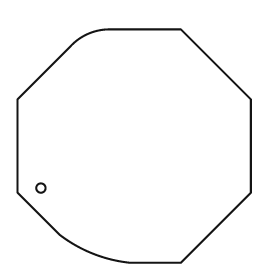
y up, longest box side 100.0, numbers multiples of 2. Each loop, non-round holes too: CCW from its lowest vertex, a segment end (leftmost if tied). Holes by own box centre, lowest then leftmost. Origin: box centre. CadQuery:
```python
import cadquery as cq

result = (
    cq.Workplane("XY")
    .moveTo(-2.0, -50.0)
    .lineTo(20.0, -50.0)
    .lineTo(50.0, -20.0)
    .lineTo(50.0, 20.0)
    .lineTo(20.0, 50.0)
    .lineTo(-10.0, 50.0)
    .threePointArc((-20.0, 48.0), (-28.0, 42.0))
    .lineTo(-50.0, 20.0)
    .lineTo(-50.0, -20.0)
    .lineTo(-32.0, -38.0)
    .threePointArc((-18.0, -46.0), (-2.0, -50.0))
    .close()
    .moveTo(-40.0, -18.0)
    .circle(2.0)
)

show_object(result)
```